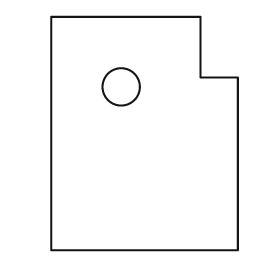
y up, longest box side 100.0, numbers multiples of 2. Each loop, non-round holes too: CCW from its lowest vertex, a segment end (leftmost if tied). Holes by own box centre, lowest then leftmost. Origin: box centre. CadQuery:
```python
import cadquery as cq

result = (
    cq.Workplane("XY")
    .moveTo(-40.0, -50.0)
    .lineTo(40.0, -50.0)
    .lineTo(40.0, 24.0)
    .lineTo(24.0, 24.0)
    .lineTo(24.0, 50.0)
    .lineTo(-40.0, 50.0)
    .close()
    .moveTo(-10.0, 20.0)
    .circle(8.0)
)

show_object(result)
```